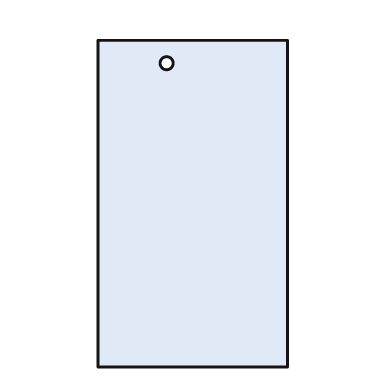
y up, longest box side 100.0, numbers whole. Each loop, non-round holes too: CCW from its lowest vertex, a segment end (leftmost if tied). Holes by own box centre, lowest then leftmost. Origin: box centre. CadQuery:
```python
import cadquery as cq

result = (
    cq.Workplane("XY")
    .moveTo(-29.0, -50.0)
    .lineTo(29.0, -50.0)
    .lineTo(29.0, 50.0)
    .lineTo(-29.0, 50.0)
    .close()
    .moveTo(-8.0, 43.0)
    .circle(2.0)
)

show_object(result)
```